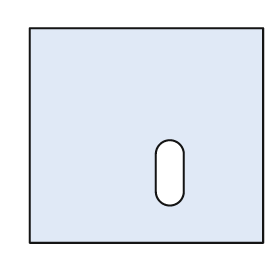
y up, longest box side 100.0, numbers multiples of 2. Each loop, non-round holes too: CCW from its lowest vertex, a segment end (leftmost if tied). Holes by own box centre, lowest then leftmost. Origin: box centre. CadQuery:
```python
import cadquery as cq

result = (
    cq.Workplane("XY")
    .moveTo(-50.0, -46.0)
    .lineTo(50.0, -46.0)
    .lineTo(50.0, 46.0)
    .lineTo(-50.0, 46.0)
    .close()
    .moveTo(4.0, -24.0)
    .threePointArc((10.0, -30.0), (16.0, -24.0))
    .lineTo(16.0, -8.0)
    .threePointArc((10.0, -2.0), (4.0, -8.0))
    .close()
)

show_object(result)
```